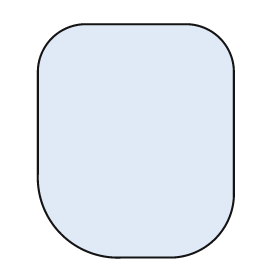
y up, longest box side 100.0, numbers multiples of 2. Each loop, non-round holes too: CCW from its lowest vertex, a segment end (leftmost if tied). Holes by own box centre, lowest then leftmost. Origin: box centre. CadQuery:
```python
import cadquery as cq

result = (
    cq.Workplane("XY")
    .moveTo(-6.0, -50.0)
    .lineTo(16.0, -50.0)
    .threePointArc((34.0, -42.0), (42.0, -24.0))
    .lineTo(42.0, 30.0)
    .threePointArc((36.0, 44.0), (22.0, 50.0))
    .lineTo(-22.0, 50.0)
    .threePointArc((-36.0, 44.0), (-42.0, 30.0))
    .lineTo(-42.0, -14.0)
    .threePointArc((-32.0, -40.0), (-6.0, -50.0))
    .close()
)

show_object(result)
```